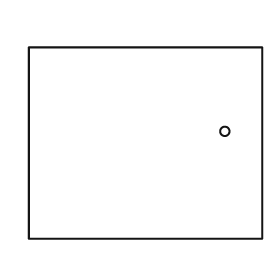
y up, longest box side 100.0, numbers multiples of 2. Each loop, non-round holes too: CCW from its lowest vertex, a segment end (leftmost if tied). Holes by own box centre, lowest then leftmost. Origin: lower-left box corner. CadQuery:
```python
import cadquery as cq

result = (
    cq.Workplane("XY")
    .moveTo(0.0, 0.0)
    .lineTo(100.0, 0.0)
    .lineTo(100.0, 82.0)
    .lineTo(0.0, 82.0)
    .close()
    .moveTo(84.0, 46.0)
    .circle(2.0)
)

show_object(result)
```